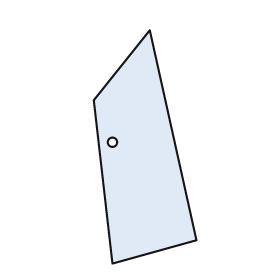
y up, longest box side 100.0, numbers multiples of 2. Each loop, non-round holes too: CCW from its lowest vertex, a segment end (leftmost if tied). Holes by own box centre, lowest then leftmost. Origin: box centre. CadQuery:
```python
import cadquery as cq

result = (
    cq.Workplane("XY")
    .moveTo(-14.0, -50.0)
    .lineTo(22.0, -40.0)
    .lineTo(2.0, 50.0)
    .lineTo(-22.0, 20.0)
    .close()
    .moveTo(-14.0, 2.0)
    .circle(2.0)
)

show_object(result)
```